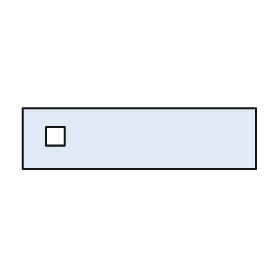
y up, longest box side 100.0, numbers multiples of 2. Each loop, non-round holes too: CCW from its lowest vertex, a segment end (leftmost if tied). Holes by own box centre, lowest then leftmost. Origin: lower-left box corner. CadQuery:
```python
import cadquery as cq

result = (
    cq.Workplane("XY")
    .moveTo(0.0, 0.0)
    .lineTo(100.0, 0.0)
    .lineTo(100.0, 26.0)
    .lineTo(0.0, 26.0)
    .close()
    .moveTo(10.0, 10.0)
    .lineTo(18.0, 10.0)
    .lineTo(18.0, 18.0)
    .lineTo(10.0, 18.0)
    .close()
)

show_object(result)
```